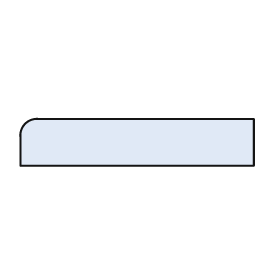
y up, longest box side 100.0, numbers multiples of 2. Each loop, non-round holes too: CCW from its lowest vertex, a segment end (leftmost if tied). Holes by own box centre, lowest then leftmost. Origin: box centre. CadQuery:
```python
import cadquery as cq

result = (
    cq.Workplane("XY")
    .moveTo(-50.0, -10.0)
    .lineTo(50.0, -10.0)
    .lineTo(50.0, 10.0)
    .lineTo(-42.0, 10.0)
    .threePointArc((-48.0, 8.0), (-50.0, 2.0))
    .close()
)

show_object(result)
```